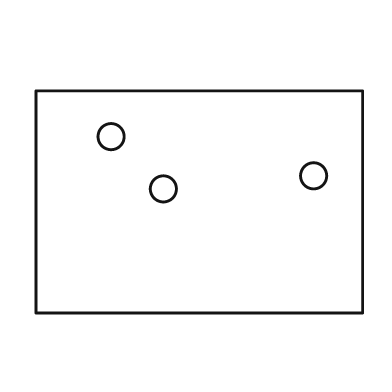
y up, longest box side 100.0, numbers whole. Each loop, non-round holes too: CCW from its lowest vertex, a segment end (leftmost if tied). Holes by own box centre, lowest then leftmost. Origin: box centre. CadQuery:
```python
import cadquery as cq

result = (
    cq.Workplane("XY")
    .moveTo(-50.0, -34.0)
    .lineTo(50.0, -34.0)
    .lineTo(50.0, 34.0)
    .lineTo(-50.0, 34.0)
    .close()
    .moveTo(-11.0, 4.0)
    .circle(4.0)
    .moveTo(35.0, 8.0)
    .circle(4.0)
    .moveTo(-27.0, 20.0)
    .circle(4.0)
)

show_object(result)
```